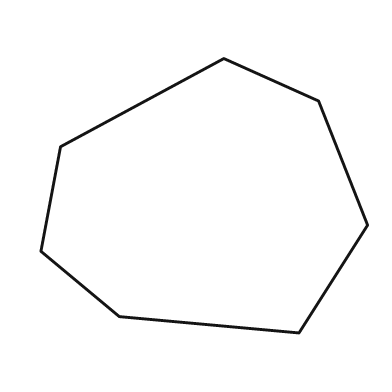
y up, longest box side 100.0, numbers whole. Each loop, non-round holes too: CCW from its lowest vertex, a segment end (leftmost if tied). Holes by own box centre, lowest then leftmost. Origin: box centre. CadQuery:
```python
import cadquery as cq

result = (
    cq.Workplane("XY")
    .moveTo(29.0, -42.0)
    .lineTo(50.0, -9.0)
    .lineTo(35.0, 29.0)
    .lineTo(6.0, 42.0)
    .lineTo(-44.0, 15.0)
    .lineTo(-50.0, -17.0)
    .lineTo(-26.0, -37.0)
    .close()
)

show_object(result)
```